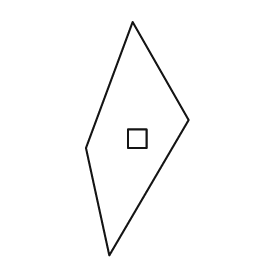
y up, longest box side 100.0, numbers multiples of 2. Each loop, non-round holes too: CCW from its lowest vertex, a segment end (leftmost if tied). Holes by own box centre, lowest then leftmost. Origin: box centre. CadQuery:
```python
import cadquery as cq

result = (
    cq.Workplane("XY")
    .moveTo(-12.0, -50.0)
    .lineTo(22.0, 8.0)
    .lineTo(-2.0, 50.0)
    .lineTo(-22.0, -4.0)
    .close()
    .moveTo(-4.0, -4.0)
    .lineTo(4.0, -4.0)
    .lineTo(4.0, 4.0)
    .lineTo(-4.0, 4.0)
    .close()
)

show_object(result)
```